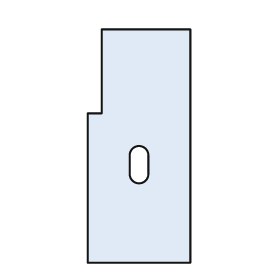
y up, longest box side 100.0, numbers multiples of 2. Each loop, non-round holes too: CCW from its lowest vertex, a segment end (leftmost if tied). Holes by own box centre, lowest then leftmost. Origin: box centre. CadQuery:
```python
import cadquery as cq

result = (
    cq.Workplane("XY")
    .moveTo(-22.0, -50.0)
    .lineTo(22.0, -50.0)
    .lineTo(22.0, 50.0)
    .lineTo(-16.0, 50.0)
    .lineTo(-16.0, 14.0)
    .lineTo(-22.0, 14.0)
    .close()
    .moveTo(-4.0, -12.0)
    .threePointArc((0.0, -16.0), (4.0, -12.0))
    .lineTo(4.0, -4.0)
    .threePointArc((0.0, 0.0), (-4.0, -4.0))
    .close()
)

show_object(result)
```